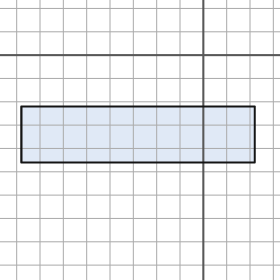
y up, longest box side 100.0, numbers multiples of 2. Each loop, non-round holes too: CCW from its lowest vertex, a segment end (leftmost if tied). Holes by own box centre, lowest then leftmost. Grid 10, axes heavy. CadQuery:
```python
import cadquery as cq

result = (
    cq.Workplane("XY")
    .moveTo(-78.0, -46.0)
    .lineTo(22.0, -46.0)
    .lineTo(22.0, -22.0)
    .lineTo(-78.0, -22.0)
    .close()
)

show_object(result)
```